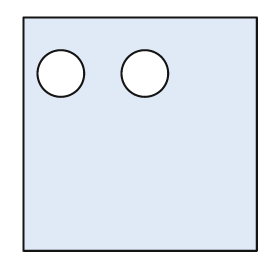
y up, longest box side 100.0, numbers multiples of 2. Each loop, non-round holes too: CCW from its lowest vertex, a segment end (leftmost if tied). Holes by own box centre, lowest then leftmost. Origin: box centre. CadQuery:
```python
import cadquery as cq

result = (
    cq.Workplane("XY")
    .moveTo(-50.0, -50.0)
    .lineTo(50.0, -50.0)
    .lineTo(50.0, 50.0)
    .lineTo(-50.0, 50.0)
    .close()
    .moveTo(-34.0, 26.0)
    .circle(10.0)
    .moveTo(2.0, 26.0)
    .circle(10.0)
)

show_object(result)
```